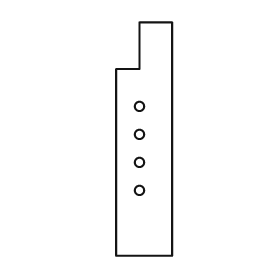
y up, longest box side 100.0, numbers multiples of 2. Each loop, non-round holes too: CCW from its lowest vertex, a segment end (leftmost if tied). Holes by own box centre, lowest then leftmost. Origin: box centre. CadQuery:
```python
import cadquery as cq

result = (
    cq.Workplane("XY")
    .moveTo(-12.0, -50.0)
    .lineTo(12.0, -50.0)
    .lineTo(12.0, 50.0)
    .lineTo(-2.0, 50.0)
    .lineTo(-2.0, 30.0)
    .lineTo(-12.0, 30.0)
    .close()
    .moveTo(-2.0, -22.0)
    .circle(2.0)
    .moveTo(-2.0, -10.0)
    .circle(2.0)
    .moveTo(-2.0, 2.0)
    .circle(2.0)
    .moveTo(-2.0, 14.0)
    .circle(2.0)
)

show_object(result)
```